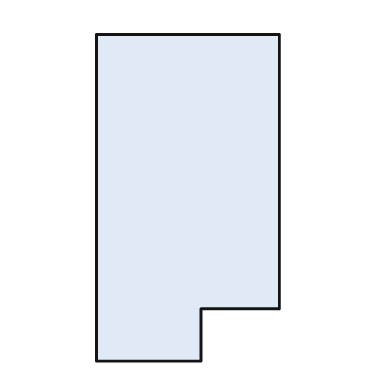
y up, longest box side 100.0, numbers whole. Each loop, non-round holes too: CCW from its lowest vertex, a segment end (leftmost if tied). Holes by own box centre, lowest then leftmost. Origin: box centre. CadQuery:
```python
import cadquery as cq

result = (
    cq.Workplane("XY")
    .moveTo(-28.0, -50.0)
    .lineTo(4.0, -50.0)
    .lineTo(4.0, -34.0)
    .lineTo(28.0, -34.0)
    .lineTo(28.0, 50.0)
    .lineTo(-28.0, 50.0)
    .close()
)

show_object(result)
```